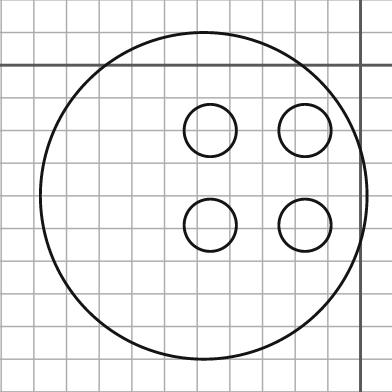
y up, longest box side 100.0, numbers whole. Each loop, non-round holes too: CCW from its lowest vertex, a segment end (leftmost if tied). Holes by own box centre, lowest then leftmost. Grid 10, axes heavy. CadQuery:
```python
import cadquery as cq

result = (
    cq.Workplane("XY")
    .moveTo(-48.0, -40.0)
    .circle(50.0)
    .moveTo(-46.0, -49.0)
    .circle(8.0)
    .moveTo(-17.0, -49.0)
    .circle(8.0)
    .moveTo(-46.0, -20.0)
    .circle(8.0)
    .moveTo(-17.0, -20.0)
    .circle(8.0)
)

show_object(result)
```